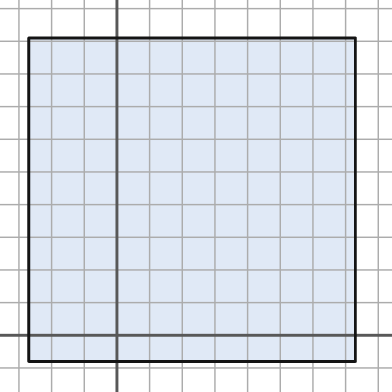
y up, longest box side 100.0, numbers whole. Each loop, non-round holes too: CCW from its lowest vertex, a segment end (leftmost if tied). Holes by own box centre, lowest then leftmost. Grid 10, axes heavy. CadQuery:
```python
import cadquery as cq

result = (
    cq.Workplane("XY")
    .moveTo(-27.0, -8.0)
    .lineTo(73.0, -8.0)
    .lineTo(73.0, 91.0)
    .lineTo(-27.0, 91.0)
    .close()
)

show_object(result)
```